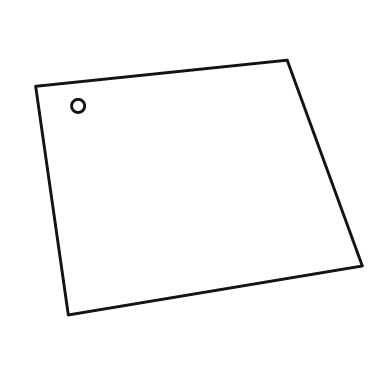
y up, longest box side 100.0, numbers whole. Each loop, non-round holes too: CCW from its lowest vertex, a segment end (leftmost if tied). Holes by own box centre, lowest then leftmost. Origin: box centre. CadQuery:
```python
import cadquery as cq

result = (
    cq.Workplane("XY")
    .moveTo(-40.0, -39.0)
    .lineTo(50.0, -24.0)
    .lineTo(27.0, 39.0)
    .lineTo(-50.0, 31.0)
    .close()
    .moveTo(-37.0, 25.0)
    .circle(2.0)
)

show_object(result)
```